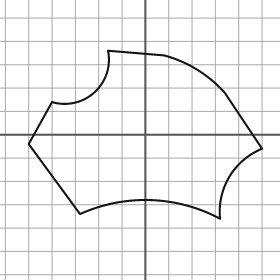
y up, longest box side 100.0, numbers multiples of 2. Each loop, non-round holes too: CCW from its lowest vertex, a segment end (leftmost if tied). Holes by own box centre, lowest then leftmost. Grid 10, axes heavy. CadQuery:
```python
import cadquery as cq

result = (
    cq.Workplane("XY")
    .moveTo(32.0, -36.0)
    .threePointArc((36.0, -18.0), (50.0, -6.0))
    .lineTo(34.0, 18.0)
    .threePointArc((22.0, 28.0), (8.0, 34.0))
    .lineTo(-16.0, 36.0)
    .threePointArc((-22.0, 18.0), (-40.0, 14.0))
    .lineTo(-50.0, -4.0)
    .lineTo(-28.0, -34.0)
    .threePointArc((2.0, -28.0), (32.0, -36.0))
    .close()
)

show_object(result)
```